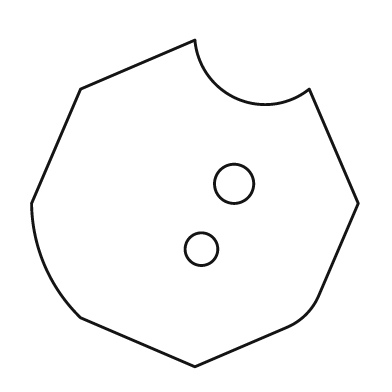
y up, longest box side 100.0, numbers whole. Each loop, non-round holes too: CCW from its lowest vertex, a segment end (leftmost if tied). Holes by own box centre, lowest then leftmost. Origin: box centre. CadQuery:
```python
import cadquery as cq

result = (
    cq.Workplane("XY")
    .moveTo(0.0, -50.0)
    .lineTo(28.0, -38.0)
    .threePointArc((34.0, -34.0), (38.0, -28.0))
    .lineTo(50.0, 0.0)
    .lineTo(35.0, 35.0)
    .threePointArc((13.0, 32.0), (0.0, 50.0))
    .lineTo(-35.0, 35.0)
    .lineTo(-50.0, 0.0)
    .threePointArc((-46.0, -19.0), (-35.0, -35.0))
    .close()
    .moveTo(2.0, -14.0)
    .circle(5.0)
    .moveTo(12.0, 6.0)
    .circle(6.0)
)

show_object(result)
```